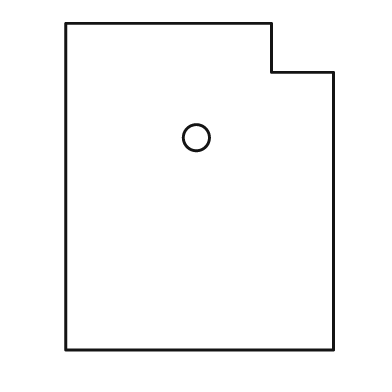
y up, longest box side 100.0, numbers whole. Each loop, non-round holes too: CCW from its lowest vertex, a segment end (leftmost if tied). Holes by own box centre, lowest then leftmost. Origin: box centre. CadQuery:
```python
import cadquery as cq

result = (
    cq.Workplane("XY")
    .moveTo(-41.0, -50.0)
    .lineTo(41.0, -50.0)
    .lineTo(41.0, 35.0)
    .lineTo(22.0, 35.0)
    .lineTo(22.0, 50.0)
    .lineTo(-41.0, 50.0)
    .close()
    .moveTo(-1.0, 15.0)
    .circle(4.0)
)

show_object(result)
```